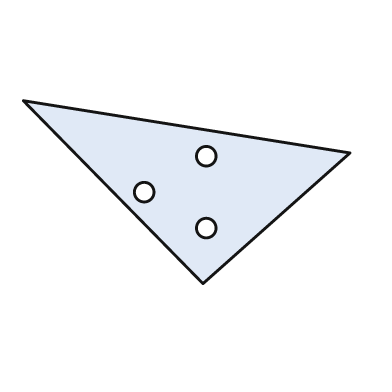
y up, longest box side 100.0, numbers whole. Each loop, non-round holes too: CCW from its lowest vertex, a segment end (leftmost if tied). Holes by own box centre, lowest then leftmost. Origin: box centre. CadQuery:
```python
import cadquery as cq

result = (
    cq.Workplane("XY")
    .moveTo(5.0, -28.0)
    .lineTo(50.0, 12.0)
    .lineTo(-50.0, 28.0)
    .close()
    .moveTo(6.0, -11.0)
    .circle(3.0)
    .moveTo(-13.0, 0.0)
    .circle(3.0)
    .moveTo(6.0, 11.0)
    .circle(3.0)
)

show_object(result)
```